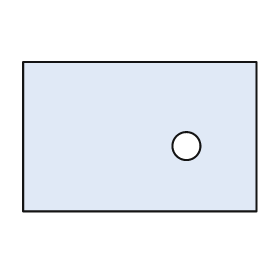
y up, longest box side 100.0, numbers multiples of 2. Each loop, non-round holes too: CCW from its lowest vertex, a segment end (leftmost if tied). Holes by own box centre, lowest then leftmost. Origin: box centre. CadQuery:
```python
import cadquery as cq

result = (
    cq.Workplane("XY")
    .moveTo(-50.0, -32.0)
    .lineTo(50.0, -32.0)
    .lineTo(50.0, 32.0)
    .lineTo(-50.0, 32.0)
    .close()
    .moveTo(20.0, -4.0)
    .circle(6.0)
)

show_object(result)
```